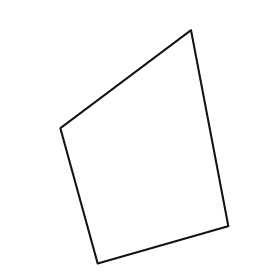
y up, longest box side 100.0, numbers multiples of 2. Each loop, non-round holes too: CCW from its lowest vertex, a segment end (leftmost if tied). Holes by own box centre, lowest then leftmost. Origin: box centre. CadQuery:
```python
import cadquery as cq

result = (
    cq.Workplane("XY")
    .moveTo(-20.0, -50.0)
    .lineTo(36.0, -34.0)
    .lineTo(20.0, 50.0)
    .lineTo(-36.0, 8.0)
    .close()
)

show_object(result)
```